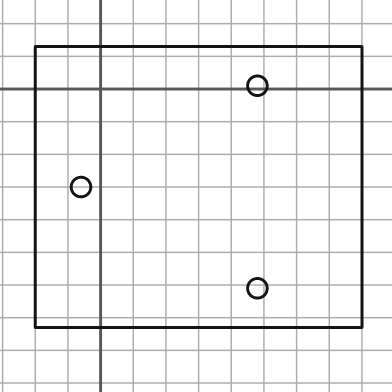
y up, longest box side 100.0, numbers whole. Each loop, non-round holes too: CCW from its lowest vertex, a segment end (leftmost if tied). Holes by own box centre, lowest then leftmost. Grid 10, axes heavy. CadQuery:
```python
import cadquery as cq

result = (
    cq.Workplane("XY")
    .moveTo(-20.0, -73.0)
    .lineTo(80.0, -73.0)
    .lineTo(80.0, 13.0)
    .lineTo(-20.0, 13.0)
    .close()
    .moveTo(48.0, -61.0)
    .circle(3.0)
    .moveTo(-6.0, -30.0)
    .circle(3.0)
    .moveTo(48.0, 1.0)
    .circle(3.0)
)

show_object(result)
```